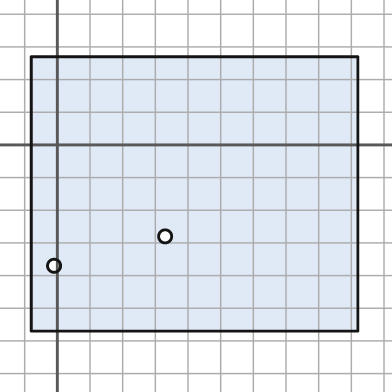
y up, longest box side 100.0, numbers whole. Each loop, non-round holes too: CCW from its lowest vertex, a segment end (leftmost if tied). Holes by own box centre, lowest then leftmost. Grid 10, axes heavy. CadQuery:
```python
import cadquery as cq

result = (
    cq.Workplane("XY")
    .moveTo(-8.0, -57.0)
    .lineTo(92.0, -57.0)
    .lineTo(92.0, 27.0)
    .lineTo(-8.0, 27.0)
    .close()
    .moveTo(-1.0, -37.0)
    .circle(2.0)
    .moveTo(33.0, -28.0)
    .circle(2.0)
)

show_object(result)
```